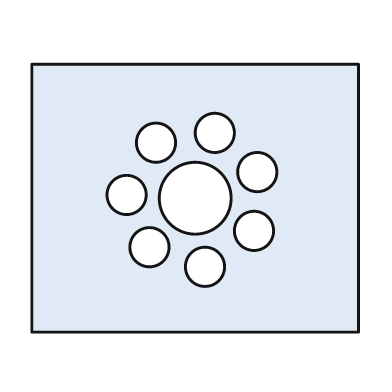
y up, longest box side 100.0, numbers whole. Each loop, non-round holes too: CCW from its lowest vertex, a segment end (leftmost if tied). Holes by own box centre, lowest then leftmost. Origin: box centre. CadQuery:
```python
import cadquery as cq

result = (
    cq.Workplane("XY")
    .moveTo(-50.0, -41.0)
    .lineTo(50.0, -41.0)
    .lineTo(50.0, 41.0)
    .lineTo(-50.0, 41.0)
    .close()
    .moveTo(3.0, -21.0)
    .circle(6.0)
    .moveTo(-14.0, -15.0)
    .circle(6.0)
    .moveTo(18.0, -10.0)
    .circle(6.0)
    .moveTo(0.0, 0.0)
    .circle(11.0)
    .moveTo(-21.0, 1.0)
    .circle(6.0)
    .moveTo(19.0, 8.0)
    .circle(6.0)
    .moveTo(-12.0, 17.0)
    .circle(6.0)
    .moveTo(6.0, 20.0)
    .circle(6.0)
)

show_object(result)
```